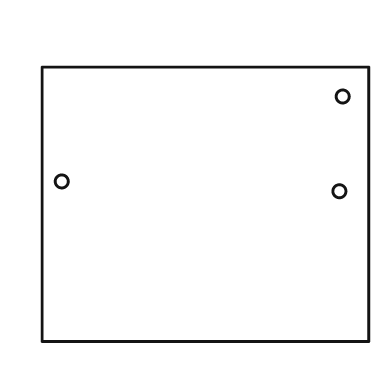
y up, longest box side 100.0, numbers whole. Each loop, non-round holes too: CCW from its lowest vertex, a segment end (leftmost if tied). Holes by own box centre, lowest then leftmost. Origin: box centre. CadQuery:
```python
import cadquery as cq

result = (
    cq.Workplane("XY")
    .moveTo(-50.0, -42.0)
    .lineTo(50.0, -42.0)
    .lineTo(50.0, 42.0)
    .lineTo(-50.0, 42.0)
    .close()
    .moveTo(41.0, 4.0)
    .circle(2.0)
    .moveTo(-44.0, 7.0)
    .circle(2.0)
    .moveTo(42.0, 33.0)
    .circle(2.0)
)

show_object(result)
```